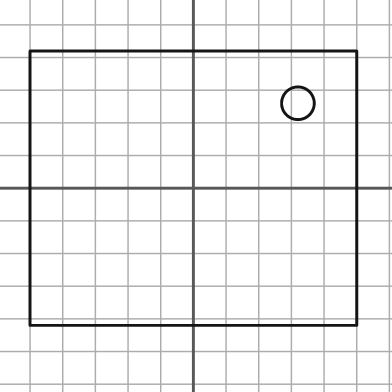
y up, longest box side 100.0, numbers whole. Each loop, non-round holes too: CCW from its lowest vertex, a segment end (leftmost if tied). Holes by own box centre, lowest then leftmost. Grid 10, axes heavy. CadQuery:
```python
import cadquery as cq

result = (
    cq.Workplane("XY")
    .moveTo(-50.0, -42.0)
    .lineTo(50.0, -42.0)
    .lineTo(50.0, 42.0)
    .lineTo(-50.0, 42.0)
    .close()
    .moveTo(32.0, 26.0)
    .circle(5.0)
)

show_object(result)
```